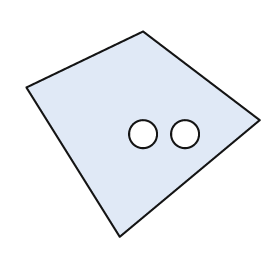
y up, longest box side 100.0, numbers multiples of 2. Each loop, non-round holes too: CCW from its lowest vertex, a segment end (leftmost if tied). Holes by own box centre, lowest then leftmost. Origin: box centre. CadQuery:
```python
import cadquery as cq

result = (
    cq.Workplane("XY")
    .moveTo(-10.0, -44.0)
    .lineTo(50.0, 6.0)
    .lineTo(0.0, 44.0)
    .lineTo(-50.0, 20.0)
    .close()
    .moveTo(0.0, 0.0)
    .circle(6.0)
    .moveTo(18.0, 0.0)
    .circle(6.0)
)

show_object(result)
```